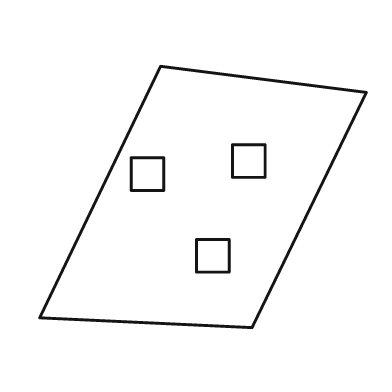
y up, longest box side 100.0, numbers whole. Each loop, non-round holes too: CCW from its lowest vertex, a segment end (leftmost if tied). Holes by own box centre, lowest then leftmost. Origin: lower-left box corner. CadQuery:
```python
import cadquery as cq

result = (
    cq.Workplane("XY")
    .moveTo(65.0, 0.0)
    .lineTo(100.0, 72.0)
    .lineTo(37.0, 80.0)
    .lineTo(0.0, 3.0)
    .close()
    .moveTo(48.0, 17.0)
    .lineTo(58.0, 17.0)
    .lineTo(58.0, 27.0)
    .lineTo(48.0, 27.0)
    .close()
    .moveTo(28.0, 42.0)
    .lineTo(38.0, 42.0)
    .lineTo(38.0, 52.0)
    .lineTo(28.0, 52.0)
    .close()
    .moveTo(59.0, 46.0)
    .lineTo(69.0, 46.0)
    .lineTo(69.0, 56.0)
    .lineTo(59.0, 56.0)
    .close()
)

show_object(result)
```